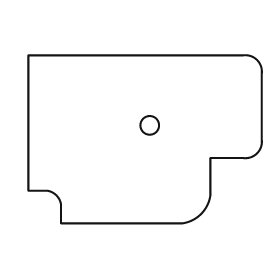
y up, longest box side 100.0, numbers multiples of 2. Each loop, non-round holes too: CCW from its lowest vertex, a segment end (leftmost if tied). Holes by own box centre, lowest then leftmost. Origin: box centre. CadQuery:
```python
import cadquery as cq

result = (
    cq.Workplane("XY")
    .moveTo(-36.0, -36.0)
    .lineTo(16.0, -36.0)
    .threePointArc((24.0, -32.0), (28.0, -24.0))
    .lineTo(28.0, -8.0)
    .lineTo(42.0, -8.0)
    .threePointArc((48.0, -6.0), (50.0, 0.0))
    .lineTo(50.0, 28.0)
    .threePointArc((48.0, 34.0), (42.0, 36.0))
    .lineTo(-50.0, 36.0)
    .lineTo(-50.0, -22.0)
    .lineTo(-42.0, -22.0)
    .threePointArc((-38.0, -24.0), (-36.0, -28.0))
    .close()
    .moveTo(2.0, 6.0)
    .circle(4.0)
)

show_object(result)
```